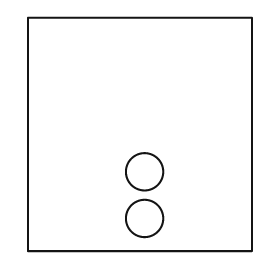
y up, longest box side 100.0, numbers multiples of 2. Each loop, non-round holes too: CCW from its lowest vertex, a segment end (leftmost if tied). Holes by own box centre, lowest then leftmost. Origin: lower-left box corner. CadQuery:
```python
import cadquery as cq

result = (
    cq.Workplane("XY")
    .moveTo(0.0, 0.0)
    .lineTo(96.0, 0.0)
    .lineTo(96.0, 100.0)
    .lineTo(0.0, 100.0)
    .close()
    .moveTo(50.0, 14.0)
    .circle(8.0)
    .moveTo(50.0, 34.0)
    .circle(8.0)
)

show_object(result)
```